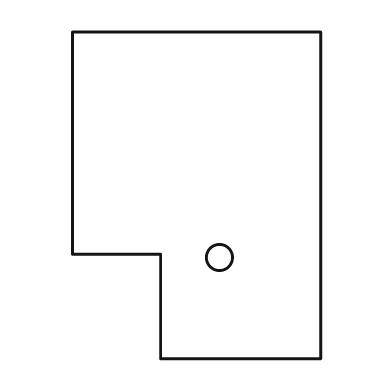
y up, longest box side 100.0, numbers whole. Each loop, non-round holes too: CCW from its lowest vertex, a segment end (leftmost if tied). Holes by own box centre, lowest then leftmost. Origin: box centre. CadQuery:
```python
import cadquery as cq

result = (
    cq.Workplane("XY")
    .moveTo(-11.0, -50.0)
    .lineTo(38.0, -50.0)
    .lineTo(38.0, 50.0)
    .lineTo(-38.0, 50.0)
    .lineTo(-38.0, -18.0)
    .lineTo(-11.0, -18.0)
    .close()
    .moveTo(7.0, -19.0)
    .circle(4.0)
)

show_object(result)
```